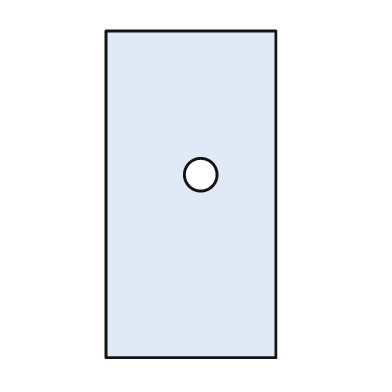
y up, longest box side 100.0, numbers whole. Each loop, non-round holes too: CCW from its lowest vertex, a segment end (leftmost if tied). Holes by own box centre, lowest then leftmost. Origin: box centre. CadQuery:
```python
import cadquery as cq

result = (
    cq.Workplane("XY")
    .moveTo(-26.0, -50.0)
    .lineTo(26.0, -50.0)
    .lineTo(26.0, 50.0)
    .lineTo(-26.0, 50.0)
    .close()
    .moveTo(3.0, 6.0)
    .circle(5.0)
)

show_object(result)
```